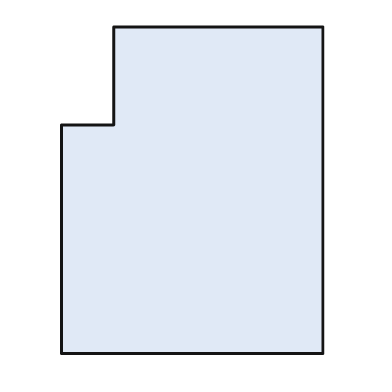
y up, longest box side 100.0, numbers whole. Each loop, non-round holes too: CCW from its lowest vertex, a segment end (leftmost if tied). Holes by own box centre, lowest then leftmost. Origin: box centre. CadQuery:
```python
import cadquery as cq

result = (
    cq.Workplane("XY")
    .moveTo(-40.0, -50.0)
    .lineTo(40.0, -50.0)
    .lineTo(40.0, 50.0)
    .lineTo(-24.0, 50.0)
    .lineTo(-24.0, 20.0)
    .lineTo(-40.0, 20.0)
    .close()
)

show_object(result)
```